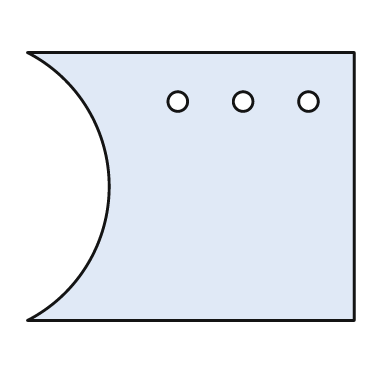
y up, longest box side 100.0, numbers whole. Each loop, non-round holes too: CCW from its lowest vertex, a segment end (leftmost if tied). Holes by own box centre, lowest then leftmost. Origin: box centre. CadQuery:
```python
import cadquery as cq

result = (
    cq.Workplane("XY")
    .moveTo(-50.0, -41.0)
    .lineTo(50.0, -41.0)
    .lineTo(50.0, 41.0)
    .lineTo(-50.0, 41.0)
    .threePointArc((-25.0, 0.0), (-50.0, -41.0))
    .close()
    .moveTo(-4.0, 26.0)
    .circle(3.0)
    .moveTo(16.0, 26.0)
    .circle(3.0)
    .moveTo(36.0, 26.0)
    .circle(3.0)
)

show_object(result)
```